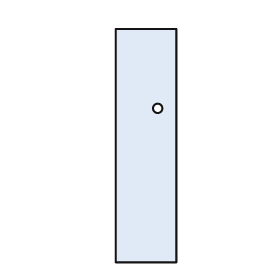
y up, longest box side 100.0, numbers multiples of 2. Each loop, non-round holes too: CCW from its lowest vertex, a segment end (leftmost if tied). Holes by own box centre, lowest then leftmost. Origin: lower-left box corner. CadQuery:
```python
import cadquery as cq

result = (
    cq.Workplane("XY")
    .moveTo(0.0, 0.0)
    .lineTo(26.0, 0.0)
    .lineTo(26.0, 100.0)
    .lineTo(0.0, 100.0)
    .close()
    .moveTo(18.0, 66.0)
    .circle(2.0)
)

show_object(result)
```